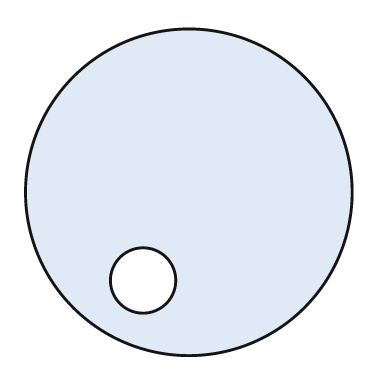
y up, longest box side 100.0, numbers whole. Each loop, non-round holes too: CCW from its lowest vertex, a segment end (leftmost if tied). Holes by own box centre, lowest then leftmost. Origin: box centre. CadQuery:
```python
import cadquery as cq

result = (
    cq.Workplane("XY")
    .moveTo(0.0, 0.0)
    .circle(50.0)
    .moveTo(-14.0, -27.0)
    .circle(10.0)
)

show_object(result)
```